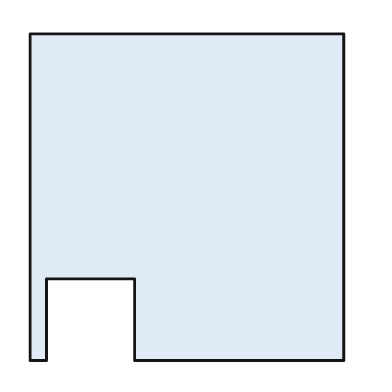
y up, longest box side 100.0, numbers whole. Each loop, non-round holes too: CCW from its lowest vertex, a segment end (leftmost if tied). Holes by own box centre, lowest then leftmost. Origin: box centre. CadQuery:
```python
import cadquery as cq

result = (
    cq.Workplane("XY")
    .moveTo(-48.0, -50.0)
    .lineTo(-43.0, -50.0)
    .lineTo(-43.0, -25.0)
    .lineTo(-16.0, -25.0)
    .lineTo(-16.0, -50.0)
    .lineTo(48.0, -50.0)
    .lineTo(48.0, 50.0)
    .lineTo(-48.0, 50.0)
    .close()
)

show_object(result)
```